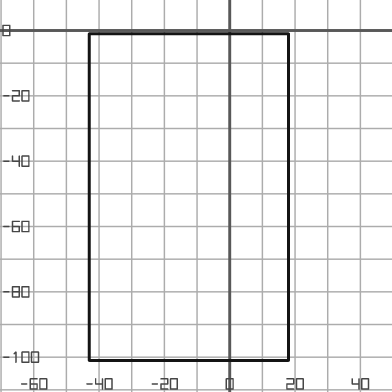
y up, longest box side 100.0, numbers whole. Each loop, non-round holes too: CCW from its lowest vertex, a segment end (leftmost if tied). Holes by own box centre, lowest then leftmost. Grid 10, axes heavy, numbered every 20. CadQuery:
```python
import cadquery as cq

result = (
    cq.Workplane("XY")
    .moveTo(-43.0, -101.0)
    .lineTo(18.0, -101.0)
    .lineTo(18.0, -1.0)
    .lineTo(-43.0, -1.0)
    .close()
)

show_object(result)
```